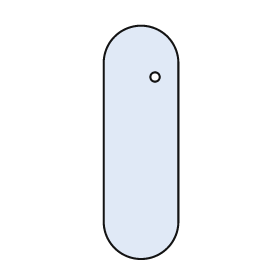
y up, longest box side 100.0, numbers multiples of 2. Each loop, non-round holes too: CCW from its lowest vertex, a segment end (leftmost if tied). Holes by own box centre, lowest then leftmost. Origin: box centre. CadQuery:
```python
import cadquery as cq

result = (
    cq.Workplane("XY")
    .moveTo(-16.0, -34.0)
    .threePointArc((0.0, -50.0), (16.0, -34.0))
    .lineTo(16.0, 34.0)
    .threePointArc((0.0, 50.0), (-16.0, 34.0))
    .close()
    .moveTo(6.0, 28.0)
    .circle(2.0)
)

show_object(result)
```